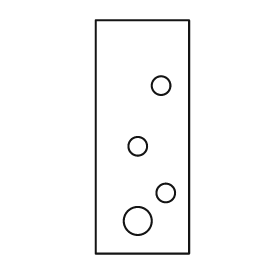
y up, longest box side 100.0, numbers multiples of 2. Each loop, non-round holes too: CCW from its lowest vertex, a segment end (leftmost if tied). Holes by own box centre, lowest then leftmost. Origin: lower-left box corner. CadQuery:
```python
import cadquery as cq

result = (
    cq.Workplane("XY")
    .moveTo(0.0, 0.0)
    .lineTo(40.0, 0.0)
    .lineTo(40.0, 100.0)
    .lineTo(0.0, 100.0)
    .close()
    .moveTo(18.0, 14.0)
    .circle(6.0)
    .moveTo(30.0, 26.0)
    .circle(4.0)
    .moveTo(18.0, 46.0)
    .circle(4.0)
    .moveTo(28.0, 72.0)
    .circle(4.0)
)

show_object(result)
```